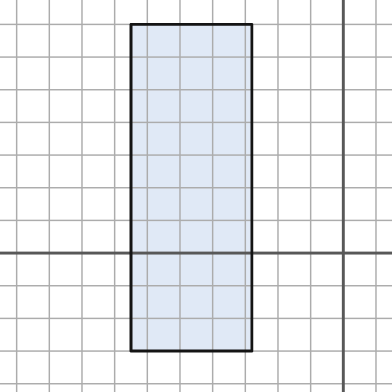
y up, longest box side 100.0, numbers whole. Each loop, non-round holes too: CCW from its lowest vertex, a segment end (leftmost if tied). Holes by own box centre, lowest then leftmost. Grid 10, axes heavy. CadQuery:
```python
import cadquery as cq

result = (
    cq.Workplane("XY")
    .moveTo(-65.0, -30.0)
    .lineTo(-28.0, -30.0)
    .lineTo(-28.0, 70.0)
    .lineTo(-65.0, 70.0)
    .close()
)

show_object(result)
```